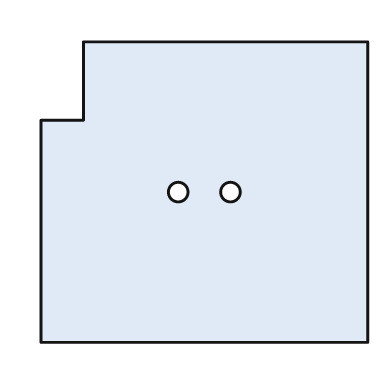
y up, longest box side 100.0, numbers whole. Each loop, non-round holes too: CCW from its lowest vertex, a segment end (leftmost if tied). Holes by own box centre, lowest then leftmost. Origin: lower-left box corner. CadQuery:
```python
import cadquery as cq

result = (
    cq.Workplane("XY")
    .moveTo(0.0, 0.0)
    .lineTo(100.0, 0.0)
    .lineTo(100.0, 92.0)
    .lineTo(13.0, 92.0)
    .lineTo(13.0, 68.0)
    .lineTo(0.0, 68.0)
    .close()
    .moveTo(42.0, 46.0)
    .circle(3.0)
    .moveTo(58.0, 46.0)
    .circle(3.0)
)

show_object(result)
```